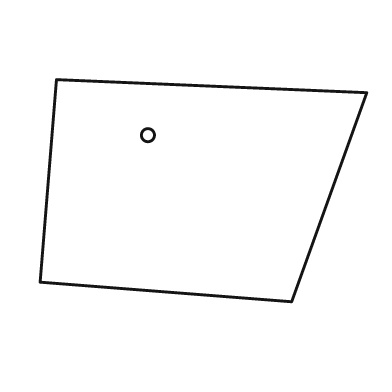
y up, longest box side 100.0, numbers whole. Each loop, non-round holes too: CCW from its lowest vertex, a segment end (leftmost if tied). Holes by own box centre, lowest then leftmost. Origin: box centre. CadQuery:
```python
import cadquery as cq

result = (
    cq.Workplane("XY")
    .moveTo(27.0, -34.0)
    .lineTo(50.0, 30.0)
    .lineTo(-45.0, 34.0)
    .lineTo(-50.0, -28.0)
    .close()
    .moveTo(-17.0, 17.0)
    .circle(2.0)
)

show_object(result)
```